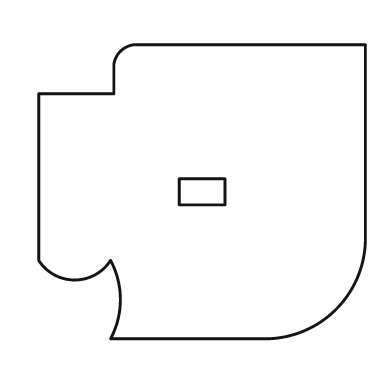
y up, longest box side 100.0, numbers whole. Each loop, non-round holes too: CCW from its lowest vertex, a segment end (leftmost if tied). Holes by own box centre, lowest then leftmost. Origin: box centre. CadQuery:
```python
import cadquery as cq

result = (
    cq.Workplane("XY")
    .moveTo(-28.0, -45.0)
    .lineTo(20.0, -45.0)
    .threePointArc((41.0, -36.0), (50.0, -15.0))
    .lineTo(50.0, 45.0)
    .lineTo(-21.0, 45.0)
    .threePointArc((-25.0, 43.0), (-27.0, 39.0))
    .lineTo(-27.0, 30.0)
    .lineTo(-50.0, 30.0)
    .lineTo(-50.0, -21.0)
    .threePointArc((-39.0, -27.0), (-28.0, -21.0))
    .threePointArc((-25.0, -33.0), (-28.0, -45.0))
    .close()
    .moveTo(-7.0, -4.0)
    .lineTo(7.0, -4.0)
    .lineTo(7.0, 4.0)
    .lineTo(-7.0, 4.0)
    .close()
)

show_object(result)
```